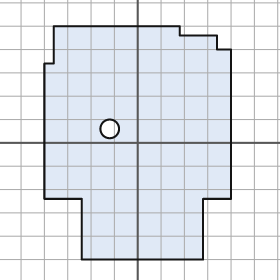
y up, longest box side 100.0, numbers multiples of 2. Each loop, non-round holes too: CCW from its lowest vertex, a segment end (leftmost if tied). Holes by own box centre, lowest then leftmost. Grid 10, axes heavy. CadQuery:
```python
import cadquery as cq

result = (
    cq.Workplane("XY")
    .moveTo(-24.0, -50.0)
    .lineTo(28.0, -50.0)
    .lineTo(28.0, -24.0)
    .lineTo(40.0, -24.0)
    .lineTo(40.0, 40.0)
    .lineTo(34.0, 40.0)
    .lineTo(34.0, 46.0)
    .lineTo(18.0, 46.0)
    .lineTo(18.0, 50.0)
    .lineTo(-36.0, 50.0)
    .lineTo(-36.0, 34.0)
    .lineTo(-40.0, 34.0)
    .lineTo(-40.0, -24.0)
    .lineTo(-24.0, -24.0)
    .close()
    .moveTo(-12.0, 6.0)
    .circle(4.0)
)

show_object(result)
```